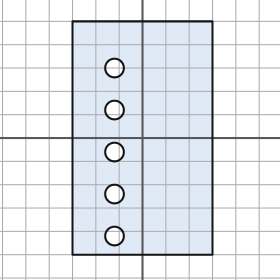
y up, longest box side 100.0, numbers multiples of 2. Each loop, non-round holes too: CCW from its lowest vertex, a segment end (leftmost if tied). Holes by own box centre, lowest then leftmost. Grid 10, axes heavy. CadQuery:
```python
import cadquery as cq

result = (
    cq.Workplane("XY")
    .moveTo(-30.0, -50.0)
    .lineTo(30.0, -50.0)
    .lineTo(30.0, 50.0)
    .lineTo(-30.0, 50.0)
    .close()
    .moveTo(-12.0, -42.0)
    .circle(4.0)
    .moveTo(-12.0, -24.0)
    .circle(4.0)
    .moveTo(-12.0, -6.0)
    .circle(4.0)
    .moveTo(-12.0, 12.0)
    .circle(4.0)
    .moveTo(-12.0, 30.0)
    .circle(4.0)
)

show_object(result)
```